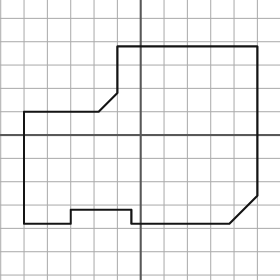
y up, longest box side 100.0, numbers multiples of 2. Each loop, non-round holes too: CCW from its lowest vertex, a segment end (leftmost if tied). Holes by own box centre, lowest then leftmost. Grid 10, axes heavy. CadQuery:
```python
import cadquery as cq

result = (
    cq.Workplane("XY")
    .moveTo(-50.0, -38.0)
    .lineTo(-30.0, -38.0)
    .lineTo(-30.0, -32.0)
    .lineTo(-4.0, -32.0)
    .lineTo(-4.0, -38.0)
    .lineTo(38.0, -38.0)
    .lineTo(50.0, -26.0)
    .lineTo(50.0, 38.0)
    .lineTo(-10.0, 38.0)
    .lineTo(-10.0, 18.0)
    .lineTo(-18.0, 10.0)
    .lineTo(-50.0, 10.0)
    .close()
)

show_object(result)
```